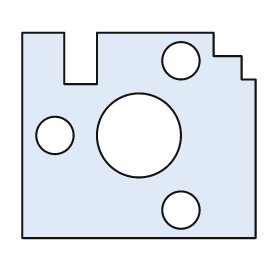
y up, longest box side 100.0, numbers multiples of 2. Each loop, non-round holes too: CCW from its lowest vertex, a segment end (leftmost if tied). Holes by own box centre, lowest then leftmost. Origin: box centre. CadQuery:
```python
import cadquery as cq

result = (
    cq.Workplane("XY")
    .moveTo(-50.0, -44.0)
    .lineTo(50.0, -44.0)
    .lineTo(50.0, 24.0)
    .lineTo(44.0, 24.0)
    .lineTo(44.0, 34.0)
    .lineTo(32.0, 34.0)
    .lineTo(32.0, 44.0)
    .lineTo(-18.0, 44.0)
    .lineTo(-18.0, 22.0)
    .lineTo(-32.0, 22.0)
    .lineTo(-32.0, 44.0)
    .lineTo(-50.0, 44.0)
    .close()
    .moveTo(18.0, -32.0)
    .circle(8.0)
    .moveTo(-36.0, 0.0)
    .circle(8.0)
    .moveTo(0.0, 0.0)
    .circle(18.0)
    .moveTo(18.0, 32.0)
    .circle(8.0)
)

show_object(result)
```